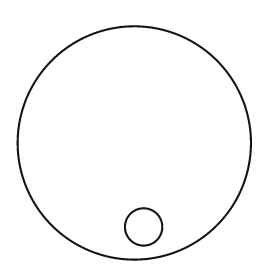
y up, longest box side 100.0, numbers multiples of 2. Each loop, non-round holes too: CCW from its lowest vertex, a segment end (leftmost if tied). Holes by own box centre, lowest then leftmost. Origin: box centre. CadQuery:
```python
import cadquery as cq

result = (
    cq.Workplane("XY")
    .moveTo(0.0, 0.0)
    .circle(50.0)
    .moveTo(4.0, -36.0)
    .circle(8.0)
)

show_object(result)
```